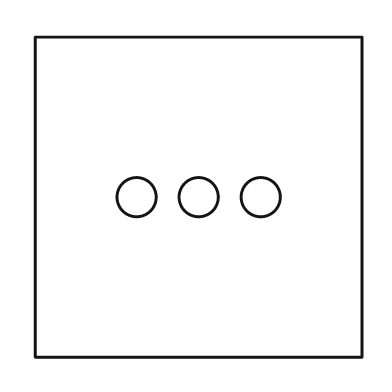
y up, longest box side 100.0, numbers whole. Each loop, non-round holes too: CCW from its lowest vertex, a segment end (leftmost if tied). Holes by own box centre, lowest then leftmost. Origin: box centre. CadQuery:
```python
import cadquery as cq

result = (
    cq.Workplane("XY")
    .moveTo(-50.0, -49.0)
    .lineTo(50.0, -49.0)
    .lineTo(50.0, 49.0)
    .lineTo(-50.0, 49.0)
    .close()
    .moveTo(-19.0, 0.0)
    .circle(6.0)
    .moveTo(0.0, 0.0)
    .circle(6.0)
    .moveTo(19.0, 0.0)
    .circle(6.0)
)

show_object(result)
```